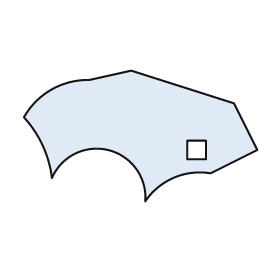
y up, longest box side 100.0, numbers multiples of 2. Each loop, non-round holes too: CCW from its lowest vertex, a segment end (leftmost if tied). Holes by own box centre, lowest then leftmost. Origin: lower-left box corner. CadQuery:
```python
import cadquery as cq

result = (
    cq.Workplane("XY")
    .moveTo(52.0, 0.0)
    .threePointArc((64.0, 10.0), (80.0, 12.0))
    .lineTo(100.0, 22.0)
    .lineTo(90.0, 42.0)
    .lineTo(46.0, 56.0)
    .lineTo(28.0, 52.0)
    .threePointArc((12.0, 48.0), (0.0, 36.0))
    .threePointArc((8.0, 24.0), (12.0, 10.0))
    .threePointArc((36.0, 22.0), (52.0, 0.0))
    .close()
    .moveTo(70.0, 18.0)
    .lineTo(78.0, 18.0)
    .lineTo(78.0, 26.0)
    .lineTo(70.0, 26.0)
    .close()
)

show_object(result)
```